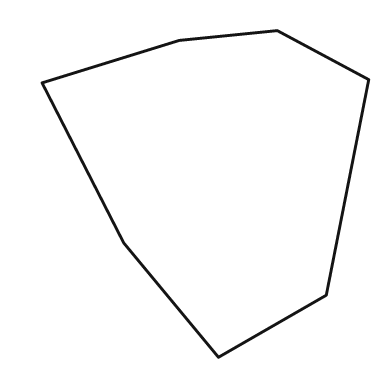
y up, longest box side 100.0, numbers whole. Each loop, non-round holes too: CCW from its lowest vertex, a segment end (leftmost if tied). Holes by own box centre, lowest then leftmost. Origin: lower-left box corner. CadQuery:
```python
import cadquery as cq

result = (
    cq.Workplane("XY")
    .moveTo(54.0, 0.0)
    .lineTo(87.0, 19.0)
    .lineTo(100.0, 85.0)
    .lineTo(72.0, 100.0)
    .lineTo(42.0, 97.0)
    .lineTo(0.0, 84.0)
    .lineTo(25.0, 35.0)
    .close()
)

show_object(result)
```